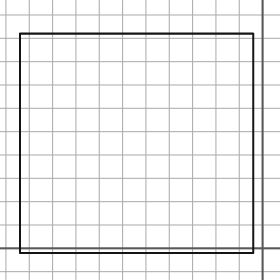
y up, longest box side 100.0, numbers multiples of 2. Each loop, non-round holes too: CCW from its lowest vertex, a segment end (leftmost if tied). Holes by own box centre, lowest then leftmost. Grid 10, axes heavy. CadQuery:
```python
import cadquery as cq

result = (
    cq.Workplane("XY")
    .moveTo(-104.0, -2.0)
    .lineTo(-4.0, -2.0)
    .lineTo(-4.0, 92.0)
    .lineTo(-104.0, 92.0)
    .close()
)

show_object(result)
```